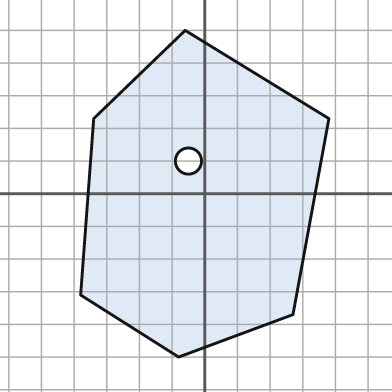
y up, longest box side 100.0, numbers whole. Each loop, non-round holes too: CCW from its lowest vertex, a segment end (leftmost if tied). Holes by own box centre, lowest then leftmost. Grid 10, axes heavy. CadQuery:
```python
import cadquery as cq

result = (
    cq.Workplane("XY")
    .moveTo(-8.0, -50.0)
    .lineTo(27.0, -37.0)
    .lineTo(38.0, 23.0)
    .lineTo(-6.0, 50.0)
    .lineTo(-34.0, 23.0)
    .lineTo(-38.0, -31.0)
    .close()
    .moveTo(-5.0, 10.0)
    .circle(4.0)
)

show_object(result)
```